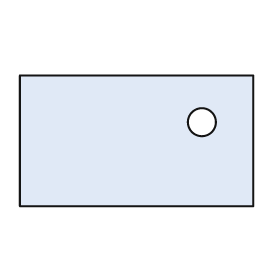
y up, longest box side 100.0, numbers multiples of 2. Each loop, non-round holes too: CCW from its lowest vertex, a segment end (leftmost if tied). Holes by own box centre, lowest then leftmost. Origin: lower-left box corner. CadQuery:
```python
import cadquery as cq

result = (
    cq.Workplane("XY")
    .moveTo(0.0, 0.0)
    .lineTo(100.0, 0.0)
    .lineTo(100.0, 56.0)
    .lineTo(0.0, 56.0)
    .close()
    .moveTo(78.0, 36.0)
    .circle(6.0)
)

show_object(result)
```